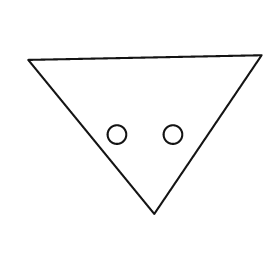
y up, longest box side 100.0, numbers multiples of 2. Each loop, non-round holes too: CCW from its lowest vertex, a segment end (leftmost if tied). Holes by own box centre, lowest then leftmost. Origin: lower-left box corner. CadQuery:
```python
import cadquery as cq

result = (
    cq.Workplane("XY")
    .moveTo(54.0, 0.0)
    .lineTo(100.0, 68.0)
    .lineTo(0.0, 66.0)
    .close()
    .moveTo(38.0, 34.0)
    .circle(4.0)
    .moveTo(62.0, 34.0)
    .circle(4.0)
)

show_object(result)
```